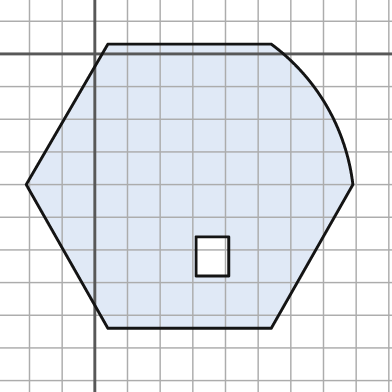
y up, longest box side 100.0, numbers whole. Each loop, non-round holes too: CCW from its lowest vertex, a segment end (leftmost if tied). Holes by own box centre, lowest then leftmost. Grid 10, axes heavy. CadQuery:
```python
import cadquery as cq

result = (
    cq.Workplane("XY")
    .moveTo(4.0, -84.0)
    .lineTo(54.0, -84.0)
    .lineTo(79.0, -40.0)
    .threePointArc((71.0, -16.0), (54.0, 3.0))
    .lineTo(4.0, 3.0)
    .lineTo(-21.0, -40.0)
    .close()
    .moveTo(31.0, -68.0)
    .lineTo(41.0, -68.0)
    .lineTo(41.0, -56.0)
    .lineTo(31.0, -56.0)
    .close()
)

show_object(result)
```